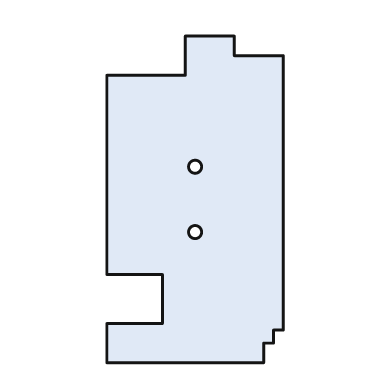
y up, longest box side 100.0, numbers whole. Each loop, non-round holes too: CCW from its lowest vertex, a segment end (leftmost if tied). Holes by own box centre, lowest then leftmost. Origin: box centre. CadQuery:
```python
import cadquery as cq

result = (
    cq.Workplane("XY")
    .moveTo(-27.0, -50.0)
    .lineTo(21.0, -50.0)
    .lineTo(21.0, -44.0)
    .lineTo(24.0, -44.0)
    .lineTo(24.0, -40.0)
    .lineTo(27.0, -40.0)
    .lineTo(27.0, 44.0)
    .lineTo(12.0, 44.0)
    .lineTo(12.0, 50.0)
    .lineTo(-3.0, 50.0)
    .lineTo(-3.0, 38.0)
    .lineTo(-27.0, 38.0)
    .lineTo(-27.0, -23.0)
    .lineTo(-10.0, -23.0)
    .lineTo(-10.0, -38.0)
    .lineTo(-27.0, -38.0)
    .close()
    .moveTo(0.0, -10.0)
    .circle(2.0)
    .moveTo(0.0, 10.0)
    .circle(2.0)
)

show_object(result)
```